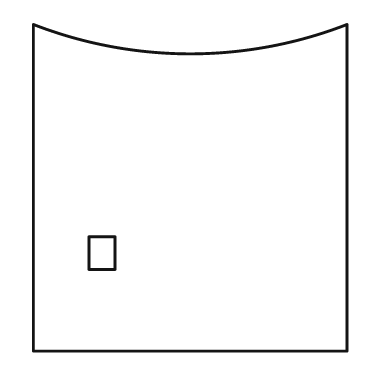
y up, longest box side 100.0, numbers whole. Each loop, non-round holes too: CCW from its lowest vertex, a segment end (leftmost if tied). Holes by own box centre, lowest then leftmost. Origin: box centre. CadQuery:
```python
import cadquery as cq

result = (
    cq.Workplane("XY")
    .moveTo(-48.0, -50.0)
    .lineTo(48.0, -50.0)
    .lineTo(48.0, 50.0)
    .threePointArc((0.0, 41.0), (-48.0, 50.0))
    .close()
    .moveTo(-31.0, -25.0)
    .lineTo(-23.0, -25.0)
    .lineTo(-23.0, -15.0)
    .lineTo(-31.0, -15.0)
    .close()
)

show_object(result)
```